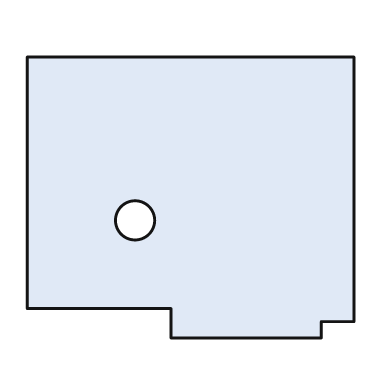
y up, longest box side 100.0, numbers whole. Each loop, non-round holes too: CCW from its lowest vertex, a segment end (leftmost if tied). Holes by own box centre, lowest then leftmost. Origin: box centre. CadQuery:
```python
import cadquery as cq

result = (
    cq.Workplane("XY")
    .moveTo(-6.0, -43.0)
    .lineTo(40.0, -43.0)
    .lineTo(40.0, -38.0)
    .lineTo(50.0, -38.0)
    .lineTo(50.0, 43.0)
    .lineTo(-50.0, 43.0)
    .lineTo(-50.0, -34.0)
    .lineTo(-6.0, -34.0)
    .close()
    .moveTo(-17.0, -7.0)
    .circle(6.0)
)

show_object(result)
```